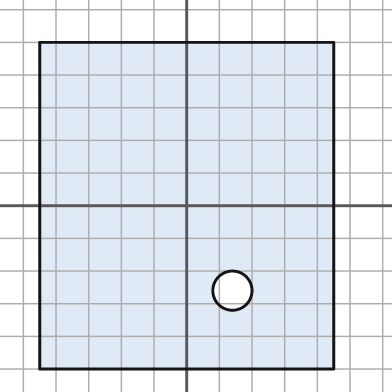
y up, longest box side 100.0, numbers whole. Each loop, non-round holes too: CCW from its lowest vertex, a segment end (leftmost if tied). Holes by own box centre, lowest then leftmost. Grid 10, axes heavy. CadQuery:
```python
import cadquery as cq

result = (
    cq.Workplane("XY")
    .moveTo(-45.0, -50.0)
    .lineTo(45.0, -50.0)
    .lineTo(45.0, 50.0)
    .lineTo(-45.0, 50.0)
    .close()
    .moveTo(14.0, -26.0)
    .circle(6.0)
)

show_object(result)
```